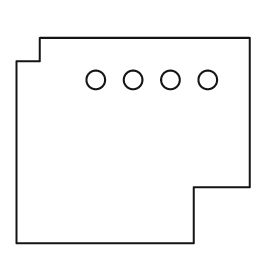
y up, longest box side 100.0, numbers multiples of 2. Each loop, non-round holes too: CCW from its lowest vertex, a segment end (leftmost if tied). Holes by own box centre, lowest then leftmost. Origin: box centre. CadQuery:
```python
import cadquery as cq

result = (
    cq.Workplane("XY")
    .moveTo(-50.0, -44.0)
    .lineTo(26.0, -44.0)
    .lineTo(26.0, -20.0)
    .lineTo(50.0, -20.0)
    .lineTo(50.0, 44.0)
    .lineTo(-40.0, 44.0)
    .lineTo(-40.0, 34.0)
    .lineTo(-50.0, 34.0)
    .close()
    .moveTo(-16.0, 26.0)
    .circle(4.0)
    .moveTo(0.0, 26.0)
    .circle(4.0)
    .moveTo(16.0, 26.0)
    .circle(4.0)
    .moveTo(32.0, 26.0)
    .circle(4.0)
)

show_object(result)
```